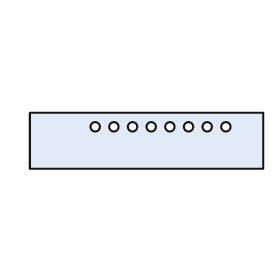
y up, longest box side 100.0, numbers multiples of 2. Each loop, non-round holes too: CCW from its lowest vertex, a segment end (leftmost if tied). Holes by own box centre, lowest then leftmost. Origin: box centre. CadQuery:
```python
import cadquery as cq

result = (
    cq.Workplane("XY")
    .moveTo(-50.0, -12.0)
    .lineTo(50.0, -12.0)
    .lineTo(50.0, 12.0)
    .lineTo(-50.0, 12.0)
    .close()
    .moveTo(-22.0, 6.0)
    .circle(2.0)
    .moveTo(-14.0, 6.0)
    .circle(2.0)
    .moveTo(-6.0, 6.0)
    .circle(2.0)
    .moveTo(2.0, 6.0)
    .circle(2.0)
    .moveTo(10.0, 6.0)
    .circle(2.0)
    .moveTo(18.0, 6.0)
    .circle(2.0)
    .moveTo(26.0, 6.0)
    .circle(2.0)
    .moveTo(34.0, 6.0)
    .circle(2.0)
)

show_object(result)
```